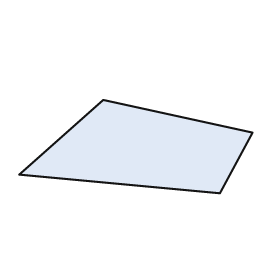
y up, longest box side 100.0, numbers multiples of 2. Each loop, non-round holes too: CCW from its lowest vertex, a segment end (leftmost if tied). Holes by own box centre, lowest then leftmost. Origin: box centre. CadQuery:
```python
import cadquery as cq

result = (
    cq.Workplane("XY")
    .moveTo(36.0, -20.0)
    .lineTo(50.0, 6.0)
    .lineTo(-14.0, 20.0)
    .lineTo(-50.0, -12.0)
    .close()
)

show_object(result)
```